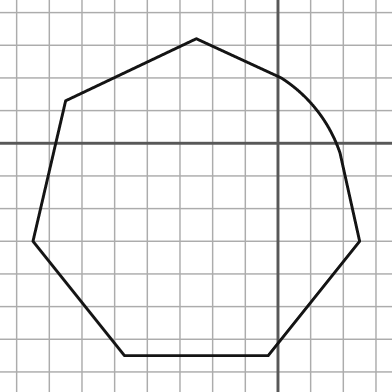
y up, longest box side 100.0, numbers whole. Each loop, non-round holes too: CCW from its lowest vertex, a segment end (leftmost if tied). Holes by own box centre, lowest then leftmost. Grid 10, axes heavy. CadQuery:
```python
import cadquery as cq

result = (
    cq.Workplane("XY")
    .moveTo(-47.0, -65.0)
    .lineTo(-3.0, -65.0)
    .lineTo(25.0, -30.0)
    .lineTo(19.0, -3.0)
    .threePointArc((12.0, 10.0), (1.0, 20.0))
    .lineTo(-25.0, 32.0)
    .lineTo(-65.0, 13.0)
    .lineTo(-75.0, -30.0)
    .close()
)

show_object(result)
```